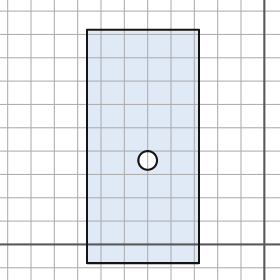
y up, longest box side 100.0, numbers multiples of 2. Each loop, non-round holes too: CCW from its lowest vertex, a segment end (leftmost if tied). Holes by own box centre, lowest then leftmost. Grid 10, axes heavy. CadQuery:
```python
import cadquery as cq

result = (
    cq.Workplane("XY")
    .moveTo(-76.0, -8.0)
    .lineTo(-28.0, -8.0)
    .lineTo(-28.0, 92.0)
    .lineTo(-76.0, 92.0)
    .close()
    .moveTo(-50.0, 36.0)
    .circle(4.0)
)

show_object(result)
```